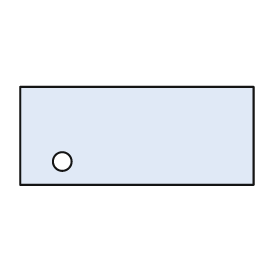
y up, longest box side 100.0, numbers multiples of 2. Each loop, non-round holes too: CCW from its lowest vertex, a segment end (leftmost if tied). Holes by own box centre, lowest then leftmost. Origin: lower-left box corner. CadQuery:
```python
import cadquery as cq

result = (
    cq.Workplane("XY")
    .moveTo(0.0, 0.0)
    .lineTo(100.0, 0.0)
    .lineTo(100.0, 42.0)
    .lineTo(0.0, 42.0)
    .close()
    .moveTo(18.0, 10.0)
    .circle(4.0)
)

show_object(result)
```